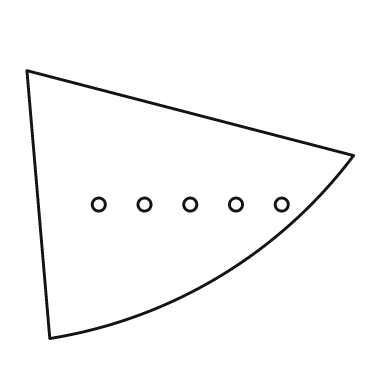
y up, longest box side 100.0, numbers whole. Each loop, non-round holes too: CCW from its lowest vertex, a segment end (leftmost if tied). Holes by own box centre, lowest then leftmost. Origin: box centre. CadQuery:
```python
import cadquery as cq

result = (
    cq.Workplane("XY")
    .moveTo(-43.0, -41.0)
    .threePointArc((9.0, -22.0), (50.0, 15.0))
    .lineTo(-50.0, 41.0)
    .close()
    .moveTo(-28.0, 0.0)
    .circle(2.0)
    .moveTo(-14.0, 0.0)
    .circle(2.0)
    .moveTo(0.0, 0.0)
    .circle(2.0)
    .moveTo(14.0, 0.0)
    .circle(2.0)
    .moveTo(28.0, 0.0)
    .circle(2.0)
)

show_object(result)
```